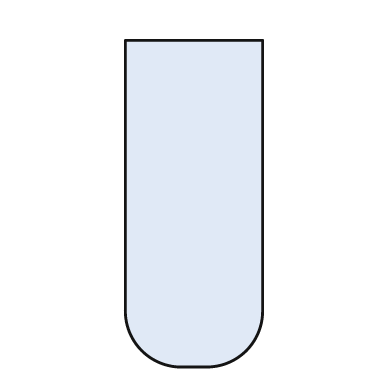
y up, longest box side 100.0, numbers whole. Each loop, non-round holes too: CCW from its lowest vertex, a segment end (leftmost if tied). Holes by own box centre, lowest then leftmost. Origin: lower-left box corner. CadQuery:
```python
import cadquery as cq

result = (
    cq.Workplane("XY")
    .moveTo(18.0, 0.0)
    .lineTo(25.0, 0.0)
    .threePointArc((37.0, 5.0), (42.0, 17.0))
    .lineTo(42.0, 100.0)
    .lineTo(0.0, 100.0)
    .lineTo(0.0, 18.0)
    .threePointArc((5.0, 5.0), (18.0, 0.0))
    .close()
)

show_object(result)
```